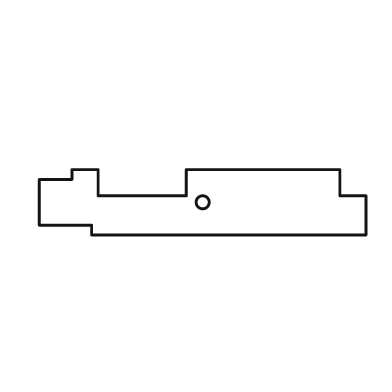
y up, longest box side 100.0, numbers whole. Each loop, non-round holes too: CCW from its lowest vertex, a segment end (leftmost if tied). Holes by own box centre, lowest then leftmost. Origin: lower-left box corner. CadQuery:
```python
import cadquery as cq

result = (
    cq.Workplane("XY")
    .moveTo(16.0, 0.0)
    .lineTo(100.0, 0.0)
    .lineTo(100.0, 12.0)
    .lineTo(92.0, 12.0)
    .lineTo(92.0, 20.0)
    .lineTo(45.0, 20.0)
    .lineTo(45.0, 12.0)
    .lineTo(18.0, 12.0)
    .lineTo(18.0, 20.0)
    .lineTo(10.0, 20.0)
    .lineTo(10.0, 17.0)
    .lineTo(0.0, 17.0)
    .lineTo(0.0, 3.0)
    .lineTo(16.0, 3.0)
    .close()
    .moveTo(50.0, 10.0)
    .circle(2.0)
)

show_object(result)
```